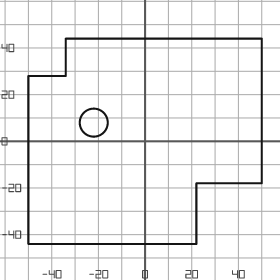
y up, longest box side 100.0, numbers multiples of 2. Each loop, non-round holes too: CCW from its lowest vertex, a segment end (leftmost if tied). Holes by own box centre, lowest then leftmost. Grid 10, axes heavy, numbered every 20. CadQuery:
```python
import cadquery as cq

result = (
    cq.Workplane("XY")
    .moveTo(-50.0, -44.0)
    .lineTo(22.0, -44.0)
    .lineTo(22.0, -18.0)
    .lineTo(50.0, -18.0)
    .lineTo(50.0, 44.0)
    .lineTo(-34.0, 44.0)
    .lineTo(-34.0, 28.0)
    .lineTo(-50.0, 28.0)
    .close()
    .moveTo(-22.0, 8.0)
    .circle(6.0)
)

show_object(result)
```